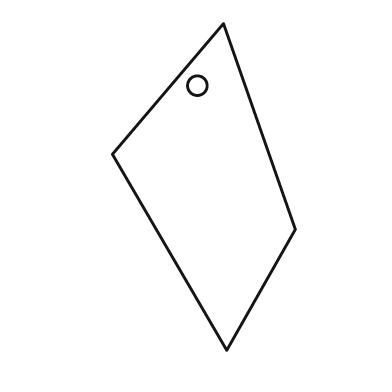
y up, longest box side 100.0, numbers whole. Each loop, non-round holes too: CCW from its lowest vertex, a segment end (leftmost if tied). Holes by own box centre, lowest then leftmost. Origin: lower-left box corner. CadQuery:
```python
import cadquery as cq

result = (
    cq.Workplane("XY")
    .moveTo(35.0, 0.0)
    .lineTo(56.0, 37.0)
    .lineTo(34.0, 100.0)
    .lineTo(0.0, 60.0)
    .close()
    .moveTo(26.0, 81.0)
    .circle(3.0)
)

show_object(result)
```